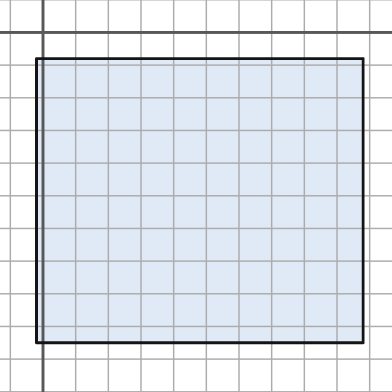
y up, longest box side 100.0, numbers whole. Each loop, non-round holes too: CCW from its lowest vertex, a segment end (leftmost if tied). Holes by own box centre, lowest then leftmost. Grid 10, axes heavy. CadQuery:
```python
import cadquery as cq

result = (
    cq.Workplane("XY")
    .moveTo(-2.0, -95.0)
    .lineTo(98.0, -95.0)
    .lineTo(98.0, -8.0)
    .lineTo(-2.0, -8.0)
    .close()
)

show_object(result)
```